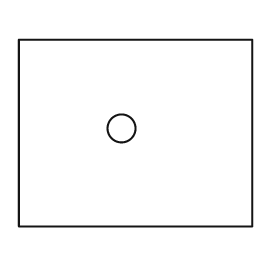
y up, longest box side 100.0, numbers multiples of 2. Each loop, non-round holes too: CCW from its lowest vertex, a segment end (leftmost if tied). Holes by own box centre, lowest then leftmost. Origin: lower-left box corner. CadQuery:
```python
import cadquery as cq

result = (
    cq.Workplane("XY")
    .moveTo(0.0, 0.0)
    .lineTo(100.0, 0.0)
    .lineTo(100.0, 80.0)
    .lineTo(0.0, 80.0)
    .close()
    .moveTo(44.0, 42.0)
    .circle(6.0)
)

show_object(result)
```